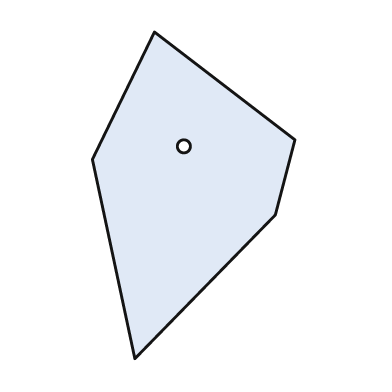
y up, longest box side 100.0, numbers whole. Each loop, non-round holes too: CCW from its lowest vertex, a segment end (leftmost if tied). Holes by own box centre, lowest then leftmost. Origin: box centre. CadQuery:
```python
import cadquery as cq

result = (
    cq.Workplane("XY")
    .moveTo(-18.0, -50.0)
    .lineTo(25.0, -6.0)
    .lineTo(31.0, 17.0)
    .lineTo(-12.0, 50.0)
    .lineTo(-31.0, 11.0)
    .close()
    .moveTo(-3.0, 15.0)
    .circle(2.0)
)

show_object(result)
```